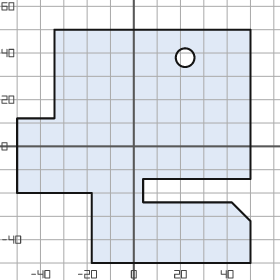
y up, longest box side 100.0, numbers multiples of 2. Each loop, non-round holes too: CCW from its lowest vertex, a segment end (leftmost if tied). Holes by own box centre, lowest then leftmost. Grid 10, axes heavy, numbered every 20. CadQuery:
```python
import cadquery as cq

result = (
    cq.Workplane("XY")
    .moveTo(-18.0, -50.0)
    .lineTo(50.0, -50.0)
    .lineTo(50.0, -32.0)
    .lineTo(42.0, -24.0)
    .lineTo(4.0, -24.0)
    .lineTo(4.0, -14.0)
    .lineTo(50.0, -14.0)
    .lineTo(50.0, 50.0)
    .lineTo(-34.0, 50.0)
    .lineTo(-34.0, 12.0)
    .lineTo(-50.0, 12.0)
    .lineTo(-50.0, -20.0)
    .lineTo(-18.0, -20.0)
    .close()
    .moveTo(22.0, 38.0)
    .circle(4.0)
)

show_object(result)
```